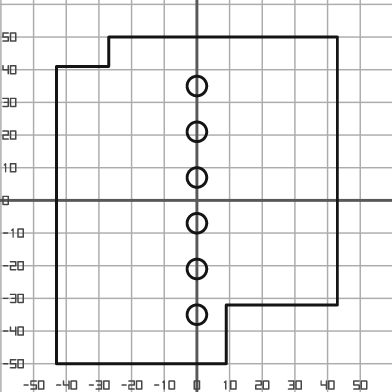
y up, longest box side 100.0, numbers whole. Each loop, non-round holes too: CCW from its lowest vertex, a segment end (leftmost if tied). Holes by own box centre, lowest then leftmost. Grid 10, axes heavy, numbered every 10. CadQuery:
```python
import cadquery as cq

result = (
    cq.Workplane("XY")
    .moveTo(-43.0, -50.0)
    .lineTo(9.0, -50.0)
    .lineTo(9.0, -32.0)
    .lineTo(43.0, -32.0)
    .lineTo(43.0, 50.0)
    .lineTo(-27.0, 50.0)
    .lineTo(-27.0, 41.0)
    .lineTo(-43.0, 41.0)
    .close()
    .moveTo(0.0, -35.0)
    .circle(3.0)
    .moveTo(0.0, -21.0)
    .circle(3.0)
    .moveTo(0.0, -7.0)
    .circle(3.0)
    .moveTo(0.0, 7.0)
    .circle(3.0)
    .moveTo(0.0, 21.0)
    .circle(3.0)
    .moveTo(0.0, 35.0)
    .circle(3.0)
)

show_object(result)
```